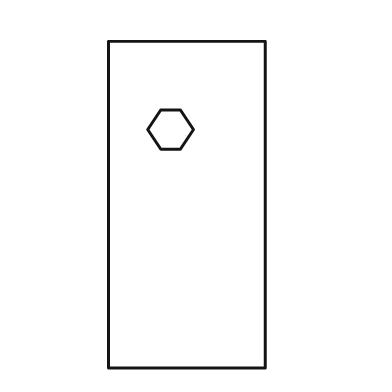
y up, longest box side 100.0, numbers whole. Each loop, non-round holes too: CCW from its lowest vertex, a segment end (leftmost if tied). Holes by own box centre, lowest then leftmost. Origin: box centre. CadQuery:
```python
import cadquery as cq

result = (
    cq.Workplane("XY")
    .moveTo(-24.0, -50.0)
    .lineTo(24.0, -50.0)
    .lineTo(24.0, 50.0)
    .lineTo(-24.0, 50.0)
    .close()
    .moveTo(-8.0, 17.0)
    .lineTo(-2.0, 17.0)
    .lineTo(2.0, 23.0)
    .lineTo(-2.0, 29.0)
    .lineTo(-8.0, 29.0)
    .lineTo(-12.0, 23.0)
    .close()
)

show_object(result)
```